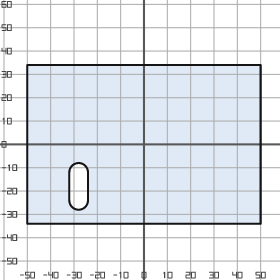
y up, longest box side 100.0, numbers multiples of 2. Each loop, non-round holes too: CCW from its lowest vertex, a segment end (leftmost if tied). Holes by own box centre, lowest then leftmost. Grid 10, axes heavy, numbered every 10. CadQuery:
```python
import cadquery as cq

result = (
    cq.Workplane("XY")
    .moveTo(-50.0, -34.0)
    .lineTo(50.0, -34.0)
    .lineTo(50.0, 34.0)
    .lineTo(-50.0, 34.0)
    .close()
    .moveTo(-32.0, -24.0)
    .threePointArc((-28.0, -28.0), (-24.0, -24.0))
    .lineTo(-24.0, -12.0)
    .threePointArc((-28.0, -8.0), (-32.0, -12.0))
    .close()
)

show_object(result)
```